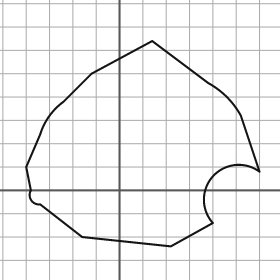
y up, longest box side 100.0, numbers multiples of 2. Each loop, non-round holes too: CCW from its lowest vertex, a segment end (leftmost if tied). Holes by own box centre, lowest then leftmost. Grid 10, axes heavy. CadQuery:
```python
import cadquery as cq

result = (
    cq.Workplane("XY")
    .moveTo(22.0, -24.0)
    .lineTo(40.0, -14.0)
    .threePointArc((40.0, 6.0), (60.0, 8.0))
    .lineTo(52.0, 32.0)
    .threePointArc((46.0, 40.0), (38.0, 46.0))
    .lineTo(14.0, 64.0)
    .lineTo(-12.0, 50.0)
    .lineTo(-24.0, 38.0)
    .threePointArc((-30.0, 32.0), (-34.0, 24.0))
    .lineTo(-40.0, 10.0)
    .lineTo(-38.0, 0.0)
    .threePointArc((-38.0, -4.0), (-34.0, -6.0))
    .lineTo(-16.0, -20.0)
    .close()
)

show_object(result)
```